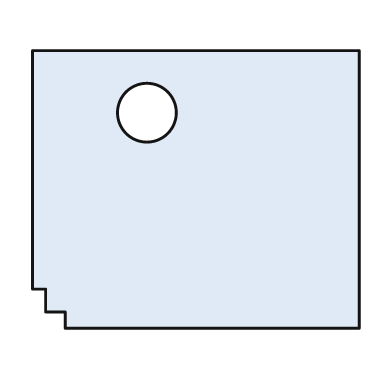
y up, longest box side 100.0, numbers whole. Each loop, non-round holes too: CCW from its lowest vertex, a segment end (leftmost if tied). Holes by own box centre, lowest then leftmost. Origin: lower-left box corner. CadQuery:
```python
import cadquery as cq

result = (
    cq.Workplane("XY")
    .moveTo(10.0, 0.0)
    .lineTo(100.0, 0.0)
    .lineTo(100.0, 85.0)
    .lineTo(0.0, 85.0)
    .lineTo(0.0, 12.0)
    .lineTo(4.0, 12.0)
    .lineTo(4.0, 5.0)
    .lineTo(10.0, 5.0)
    .close()
    .moveTo(35.0, 66.0)
    .circle(9.0)
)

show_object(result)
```